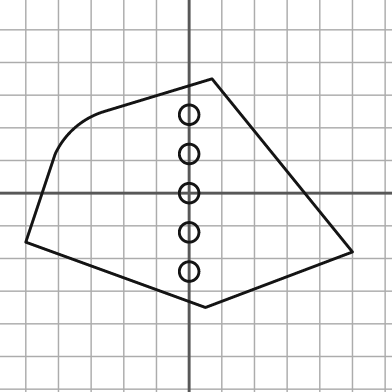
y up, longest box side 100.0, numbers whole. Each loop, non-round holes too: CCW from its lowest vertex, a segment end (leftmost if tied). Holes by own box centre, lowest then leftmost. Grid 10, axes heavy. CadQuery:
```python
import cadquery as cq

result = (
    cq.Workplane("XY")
    .moveTo(5.0, -35.0)
    .lineTo(50.0, -18.0)
    .lineTo(7.0, 35.0)
    .lineTo(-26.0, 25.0)
    .threePointArc((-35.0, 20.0), (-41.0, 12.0))
    .lineTo(-50.0, -15.0)
    .close()
    .moveTo(0.0, -24.0)
    .circle(3.0)
    .moveTo(0.0, -12.0)
    .circle(3.0)
    .moveTo(0.0, 0.0)
    .circle(3.0)
    .moveTo(0.0, 12.0)
    .circle(3.0)
    .moveTo(0.0, 24.0)
    .circle(3.0)
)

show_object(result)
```